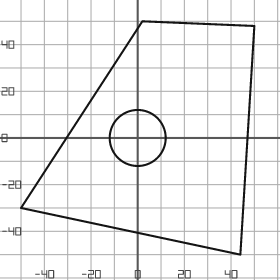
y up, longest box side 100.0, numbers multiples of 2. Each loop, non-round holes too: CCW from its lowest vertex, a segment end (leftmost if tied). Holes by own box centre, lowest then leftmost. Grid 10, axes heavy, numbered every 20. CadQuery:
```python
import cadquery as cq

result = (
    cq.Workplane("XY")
    .moveTo(44.0, -50.0)
    .lineTo(50.0, 48.0)
    .lineTo(2.0, 50.0)
    .lineTo(-50.0, -30.0)
    .close()
    .moveTo(0.0, 0.0)
    .circle(12.0)
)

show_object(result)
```